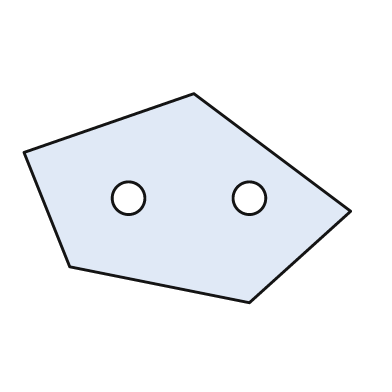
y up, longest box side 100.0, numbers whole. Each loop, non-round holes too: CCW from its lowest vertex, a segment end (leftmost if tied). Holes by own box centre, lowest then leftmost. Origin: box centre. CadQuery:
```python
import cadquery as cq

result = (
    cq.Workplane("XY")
    .moveTo(19.0, -32.0)
    .lineTo(50.0, -4.0)
    .lineTo(2.0, 32.0)
    .lineTo(-50.0, 14.0)
    .lineTo(-36.0, -21.0)
    .close()
    .moveTo(-18.0, 0.0)
    .circle(5.0)
    .moveTo(19.0, 0.0)
    .circle(5.0)
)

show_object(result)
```